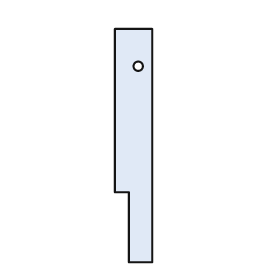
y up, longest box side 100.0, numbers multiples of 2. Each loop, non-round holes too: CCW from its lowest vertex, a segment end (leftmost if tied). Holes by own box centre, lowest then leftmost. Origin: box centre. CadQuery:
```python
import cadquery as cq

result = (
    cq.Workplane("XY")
    .moveTo(-2.0, -50.0)
    .lineTo(8.0, -50.0)
    .lineTo(8.0, 50.0)
    .lineTo(-8.0, 50.0)
    .lineTo(-8.0, -20.0)
    .lineTo(-2.0, -20.0)
    .close()
    .moveTo(2.0, 34.0)
    .circle(2.0)
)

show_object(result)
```